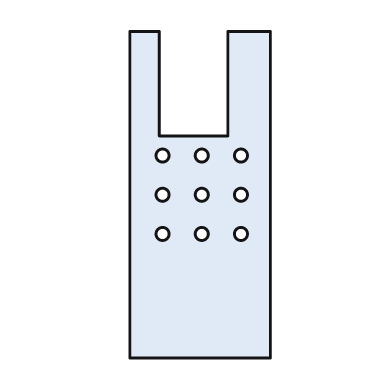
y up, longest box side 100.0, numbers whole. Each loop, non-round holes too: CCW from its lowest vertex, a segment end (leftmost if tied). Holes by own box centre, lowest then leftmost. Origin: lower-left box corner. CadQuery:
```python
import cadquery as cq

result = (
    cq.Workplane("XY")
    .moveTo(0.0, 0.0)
    .lineTo(43.0, 0.0)
    .lineTo(43.0, 100.0)
    .lineTo(30.0, 100.0)
    .lineTo(30.0, 68.0)
    .lineTo(9.0, 68.0)
    .lineTo(9.0, 100.0)
    .lineTo(0.0, 100.0)
    .close()
    .moveTo(10.0, 38.0)
    .circle(2.0)
    .moveTo(22.0, 38.0)
    .circle(2.0)
    .moveTo(34.0, 38.0)
    .circle(2.0)
    .moveTo(10.0, 50.0)
    .circle(2.0)
    .moveTo(22.0, 50.0)
    .circle(2.0)
    .moveTo(34.0, 50.0)
    .circle(2.0)
    .moveTo(10.0, 62.0)
    .circle(2.0)
    .moveTo(22.0, 62.0)
    .circle(2.0)
    .moveTo(34.0, 62.0)
    .circle(2.0)
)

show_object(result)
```